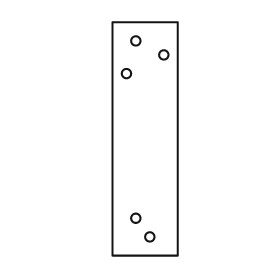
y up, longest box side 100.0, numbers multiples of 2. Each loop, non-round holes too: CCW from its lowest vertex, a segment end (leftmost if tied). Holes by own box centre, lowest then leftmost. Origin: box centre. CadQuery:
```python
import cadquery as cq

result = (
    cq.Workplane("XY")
    .moveTo(-14.0, -50.0)
    .lineTo(14.0, -50.0)
    .lineTo(14.0, 50.0)
    .lineTo(-14.0, 50.0)
    .close()
    .moveTo(2.0, -42.0)
    .circle(2.0)
    .moveTo(-4.0, -34.0)
    .circle(2.0)
    .moveTo(-8.0, 28.0)
    .circle(2.0)
    .moveTo(8.0, 36.0)
    .circle(2.0)
    .moveTo(-4.0, 42.0)
    .circle(2.0)
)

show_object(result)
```